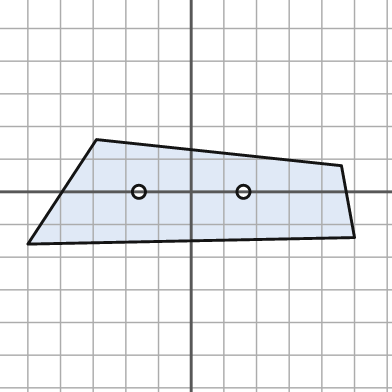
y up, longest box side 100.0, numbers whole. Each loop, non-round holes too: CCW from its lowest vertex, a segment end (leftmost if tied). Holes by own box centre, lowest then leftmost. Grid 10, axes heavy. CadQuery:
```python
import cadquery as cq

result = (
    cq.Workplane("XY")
    .moveTo(-50.0, -16.0)
    .lineTo(50.0, -14.0)
    .lineTo(46.0, 8.0)
    .lineTo(-29.0, 16.0)
    .close()
    .moveTo(-16.0, 0.0)
    .circle(2.0)
    .moveTo(16.0, 0.0)
    .circle(2.0)
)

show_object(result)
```